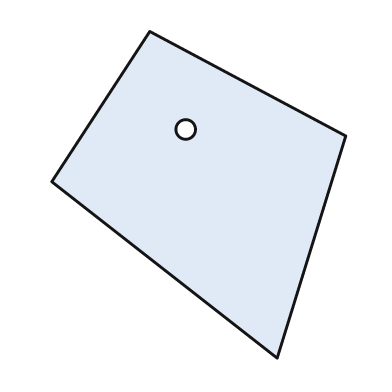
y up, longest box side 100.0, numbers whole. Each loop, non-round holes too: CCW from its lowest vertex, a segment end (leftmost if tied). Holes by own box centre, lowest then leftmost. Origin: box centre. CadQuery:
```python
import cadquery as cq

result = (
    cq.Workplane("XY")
    .moveTo(24.0, -50.0)
    .lineTo(45.0, 18.0)
    .lineTo(-15.0, 50.0)
    .lineTo(-45.0, 4.0)
    .close()
    .moveTo(-4.0, 20.0)
    .circle(3.0)
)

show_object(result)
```